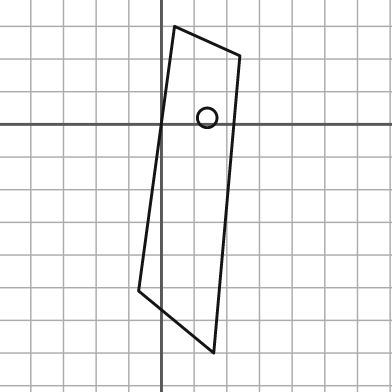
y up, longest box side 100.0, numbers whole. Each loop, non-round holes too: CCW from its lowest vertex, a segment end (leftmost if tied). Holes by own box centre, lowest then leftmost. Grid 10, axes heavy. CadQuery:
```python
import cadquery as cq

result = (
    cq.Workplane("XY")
    .moveTo(16.0, -70.0)
    .lineTo(24.0, 21.0)
    .lineTo(4.0, 30.0)
    .lineTo(-7.0, -51.0)
    .close()
    .moveTo(14.0, 2.0)
    .circle(3.0)
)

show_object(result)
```